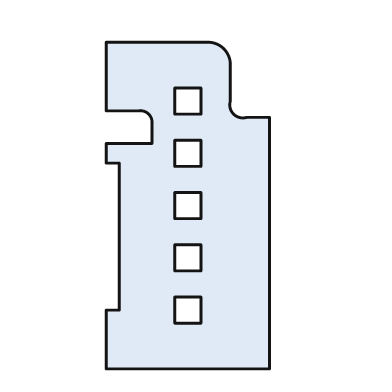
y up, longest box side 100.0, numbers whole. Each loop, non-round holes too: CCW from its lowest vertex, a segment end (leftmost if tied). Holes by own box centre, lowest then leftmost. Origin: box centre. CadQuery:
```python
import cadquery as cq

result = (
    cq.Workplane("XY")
    .moveTo(-25.0, -50.0)
    .lineTo(25.0, -50.0)
    .lineTo(25.0, 27.0)
    .lineTo(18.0, 27.0)
    .threePointArc((14.0, 28.0), (13.0, 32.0))
    .lineTo(13.0, 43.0)
    .threePointArc((11.0, 48.0), (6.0, 50.0))
    .lineTo(-25.0, 50.0)
    .lineTo(-25.0, 29.0)
    .lineTo(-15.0, 29.0)
    .threePointArc((-12.0, 28.0), (-11.0, 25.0))
    .lineTo(-11.0, 19.0)
    .lineTo(-25.0, 19.0)
    .lineTo(-25.0, 13.0)
    .lineTo(-21.0, 13.0)
    .lineTo(-21.0, -32.0)
    .lineTo(-25.0, -32.0)
    .close()
    .moveTo(-4.0, -36.0)
    .lineTo(4.0, -36.0)
    .lineTo(4.0, -28.0)
    .lineTo(-4.0, -28.0)
    .close()
    .moveTo(-4.0, -20.0)
    .lineTo(4.0, -20.0)
    .lineTo(4.0, -12.0)
    .lineTo(-4.0, -12.0)
    .close()
    .moveTo(-4.0, -4.0)
    .lineTo(4.0, -4.0)
    .lineTo(4.0, 4.0)
    .lineTo(-4.0, 4.0)
    .close()
    .moveTo(-4.0, 12.0)
    .lineTo(4.0, 12.0)
    .lineTo(4.0, 20.0)
    .lineTo(-4.0, 20.0)
    .close()
    .moveTo(-4.0, 28.0)
    .lineTo(4.0, 28.0)
    .lineTo(4.0, 36.0)
    .lineTo(-4.0, 36.0)
    .close()
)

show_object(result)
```